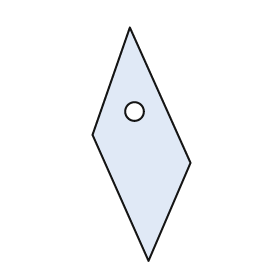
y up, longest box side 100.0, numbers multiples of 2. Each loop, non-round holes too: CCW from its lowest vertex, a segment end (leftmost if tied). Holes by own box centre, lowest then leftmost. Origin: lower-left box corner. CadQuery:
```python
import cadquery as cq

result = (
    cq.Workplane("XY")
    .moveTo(24.0, 0.0)
    .lineTo(42.0, 42.0)
    .lineTo(16.0, 100.0)
    .lineTo(0.0, 54.0)
    .close()
    .moveTo(18.0, 64.0)
    .circle(4.0)
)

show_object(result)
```